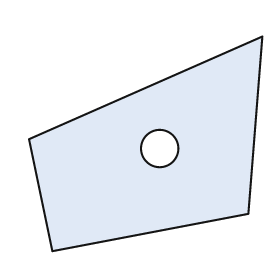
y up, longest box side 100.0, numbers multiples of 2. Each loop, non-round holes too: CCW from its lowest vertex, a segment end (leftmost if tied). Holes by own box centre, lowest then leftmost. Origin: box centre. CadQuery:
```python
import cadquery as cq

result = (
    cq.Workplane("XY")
    .moveTo(-40.0, -46.0)
    .lineTo(44.0, -30.0)
    .lineTo(50.0, 46.0)
    .lineTo(-50.0, 2.0)
    .close()
    .moveTo(6.0, -2.0)
    .circle(8.0)
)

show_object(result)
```